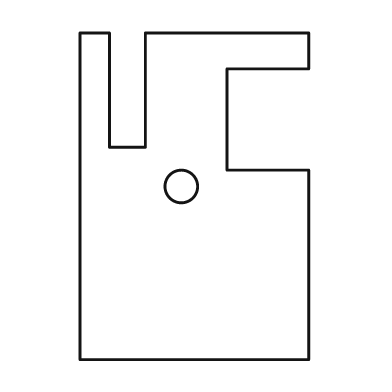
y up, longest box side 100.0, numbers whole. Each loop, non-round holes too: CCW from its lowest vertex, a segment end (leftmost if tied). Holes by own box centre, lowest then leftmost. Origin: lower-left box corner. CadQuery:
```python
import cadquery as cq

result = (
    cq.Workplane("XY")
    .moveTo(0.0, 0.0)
    .lineTo(70.0, 0.0)
    .lineTo(70.0, 58.0)
    .lineTo(45.0, 58.0)
    .lineTo(45.0, 89.0)
    .lineTo(70.0, 89.0)
    .lineTo(70.0, 100.0)
    .lineTo(20.0, 100.0)
    .lineTo(20.0, 65.0)
    .lineTo(9.0, 65.0)
    .lineTo(9.0, 100.0)
    .lineTo(0.0, 100.0)
    .close()
    .moveTo(31.0, 53.0)
    .circle(5.0)
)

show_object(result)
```